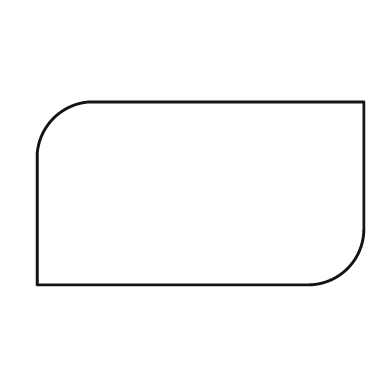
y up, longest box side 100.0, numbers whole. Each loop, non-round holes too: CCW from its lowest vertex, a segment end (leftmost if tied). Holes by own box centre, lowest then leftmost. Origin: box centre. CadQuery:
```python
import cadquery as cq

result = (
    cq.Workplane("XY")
    .moveTo(-50.0, -28.0)
    .lineTo(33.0, -28.0)
    .threePointArc((45.0, -23.0), (50.0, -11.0))
    .lineTo(50.0, 28.0)
    .lineTo(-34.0, 28.0)
    .threePointArc((-45.0, 23.0), (-50.0, 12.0))
    .close()
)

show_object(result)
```